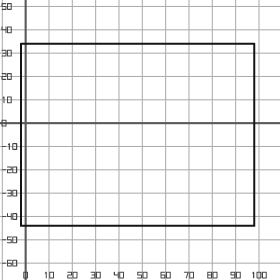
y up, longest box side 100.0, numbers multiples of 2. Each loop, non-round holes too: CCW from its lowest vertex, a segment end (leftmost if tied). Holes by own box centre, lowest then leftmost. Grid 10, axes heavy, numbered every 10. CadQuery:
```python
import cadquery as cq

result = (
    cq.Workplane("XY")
    .moveTo(-2.0, -44.0)
    .lineTo(98.0, -44.0)
    .lineTo(98.0, 34.0)
    .lineTo(-2.0, 34.0)
    .close()
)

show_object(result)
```